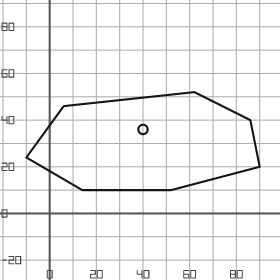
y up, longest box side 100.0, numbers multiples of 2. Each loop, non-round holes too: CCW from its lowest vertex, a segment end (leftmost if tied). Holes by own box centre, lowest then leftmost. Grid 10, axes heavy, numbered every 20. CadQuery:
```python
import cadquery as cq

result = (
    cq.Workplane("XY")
    .moveTo(14.0, 10.0)
    .lineTo(52.0, 10.0)
    .lineTo(90.0, 20.0)
    .lineTo(86.0, 40.0)
    .lineTo(62.0, 52.0)
    .lineTo(6.0, 46.0)
    .lineTo(-10.0, 24.0)
    .close()
    .moveTo(40.0, 36.0)
    .circle(2.0)
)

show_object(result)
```